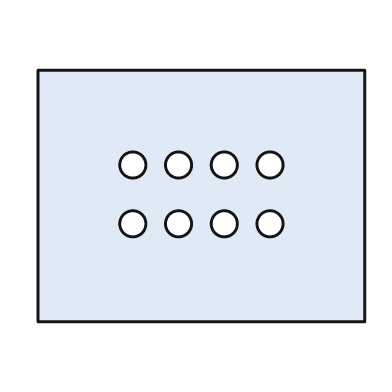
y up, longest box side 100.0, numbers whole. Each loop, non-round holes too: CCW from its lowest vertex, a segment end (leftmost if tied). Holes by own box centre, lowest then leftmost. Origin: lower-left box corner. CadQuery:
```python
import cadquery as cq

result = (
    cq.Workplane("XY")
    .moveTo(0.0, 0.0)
    .lineTo(100.0, 0.0)
    .lineTo(100.0, 77.0)
    .lineTo(0.0, 77.0)
    .close()
    .moveTo(29.0, 30.0)
    .circle(4.0)
    .moveTo(43.0, 30.0)
    .circle(4.0)
    .moveTo(57.0, 30.0)
    .circle(4.0)
    .moveTo(71.0, 30.0)
    .circle(4.0)
    .moveTo(29.0, 48.0)
    .circle(4.0)
    .moveTo(43.0, 48.0)
    .circle(4.0)
    .moveTo(57.0, 48.0)
    .circle(4.0)
    .moveTo(71.0, 48.0)
    .circle(4.0)
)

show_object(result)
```